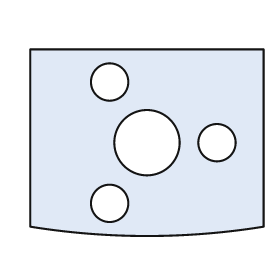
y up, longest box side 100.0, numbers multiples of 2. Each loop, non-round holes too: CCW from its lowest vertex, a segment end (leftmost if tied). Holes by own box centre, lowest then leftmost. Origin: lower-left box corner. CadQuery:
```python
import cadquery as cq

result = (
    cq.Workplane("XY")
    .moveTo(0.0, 4.0)
    .threePointArc((50.0, 0.0), (100.0, 4.0))
    .lineTo(100.0, 80.0)
    .lineTo(0.0, 80.0)
    .close()
    .moveTo(34.0, 14.0)
    .circle(8.0)
    .moveTo(50.0, 40.0)
    .circle(14.0)
    .moveTo(80.0, 40.0)
    .circle(8.0)
    .moveTo(34.0, 66.0)
    .circle(8.0)
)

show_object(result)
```